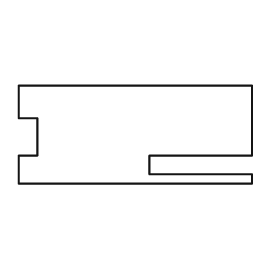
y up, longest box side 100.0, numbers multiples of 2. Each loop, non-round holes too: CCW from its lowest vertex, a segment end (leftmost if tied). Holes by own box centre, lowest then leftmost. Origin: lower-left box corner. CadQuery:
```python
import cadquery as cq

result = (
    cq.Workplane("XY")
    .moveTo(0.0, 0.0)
    .lineTo(100.0, 0.0)
    .lineTo(100.0, 4.0)
    .lineTo(56.0, 4.0)
    .lineTo(56.0, 12.0)
    .lineTo(100.0, 12.0)
    .lineTo(100.0, 42.0)
    .lineTo(0.0, 42.0)
    .lineTo(0.0, 28.0)
    .lineTo(8.0, 28.0)
    .lineTo(8.0, 12.0)
    .lineTo(0.0, 12.0)
    .close()
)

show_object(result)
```